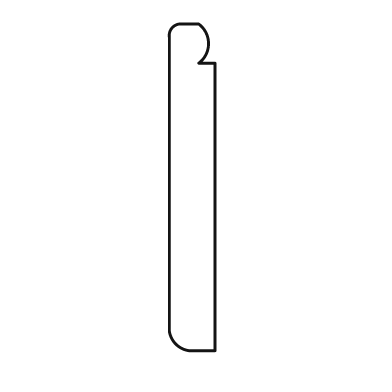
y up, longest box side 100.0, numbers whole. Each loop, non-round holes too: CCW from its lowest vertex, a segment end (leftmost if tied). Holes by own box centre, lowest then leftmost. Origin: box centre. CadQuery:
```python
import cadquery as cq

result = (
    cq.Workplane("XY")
    .moveTo(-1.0, -50.0)
    .lineTo(7.0, -50.0)
    .lineTo(7.0, 38.0)
    .lineTo(2.0, 38.0)
    .threePointArc((5.0, 44.0), (2.0, 50.0))
    .lineTo(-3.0, 50.0)
    .threePointArc((-6.0, 49.0), (-7.0, 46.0))
    .lineTo(-7.0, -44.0)
    .threePointArc((-5.0, -48.0), (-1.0, -50.0))
    .close()
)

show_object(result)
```